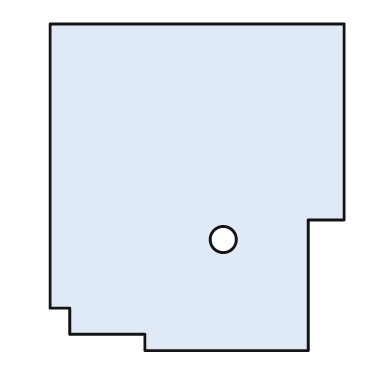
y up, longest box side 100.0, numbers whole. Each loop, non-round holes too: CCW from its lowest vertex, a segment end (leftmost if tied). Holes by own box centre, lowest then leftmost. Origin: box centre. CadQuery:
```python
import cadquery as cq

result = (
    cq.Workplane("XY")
    .moveTo(-16.0, -50.0)
    .lineTo(34.0, -50.0)
    .lineTo(34.0, -10.0)
    .lineTo(45.0, -10.0)
    .lineTo(45.0, 50.0)
    .lineTo(-45.0, 50.0)
    .lineTo(-45.0, -37.0)
    .lineTo(-39.0, -37.0)
    .lineTo(-39.0, -45.0)
    .lineTo(-16.0, -45.0)
    .close()
    .moveTo(8.0, -16.0)
    .circle(4.0)
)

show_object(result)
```